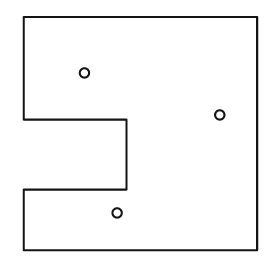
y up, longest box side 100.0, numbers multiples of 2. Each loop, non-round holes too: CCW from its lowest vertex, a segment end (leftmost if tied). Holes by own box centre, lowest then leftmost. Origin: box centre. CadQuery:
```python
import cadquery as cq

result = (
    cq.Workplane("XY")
    .moveTo(-50.0, -50.0)
    .lineTo(50.0, -50.0)
    .lineTo(50.0, 50.0)
    .lineTo(-50.0, 50.0)
    .lineTo(-50.0, 6.0)
    .lineTo(-6.0, 6.0)
    .lineTo(-6.0, -24.0)
    .lineTo(-50.0, -24.0)
    .close()
    .moveTo(-10.0, -34.0)
    .circle(2.0)
    .moveTo(34.0, 8.0)
    .circle(2.0)
    .moveTo(-24.0, 26.0)
    .circle(2.0)
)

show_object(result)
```